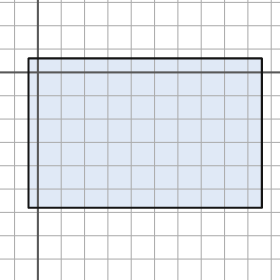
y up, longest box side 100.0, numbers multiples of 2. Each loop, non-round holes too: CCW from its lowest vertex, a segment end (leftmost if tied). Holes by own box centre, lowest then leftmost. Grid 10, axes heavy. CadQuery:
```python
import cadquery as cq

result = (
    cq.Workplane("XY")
    .moveTo(-4.0, -58.0)
    .lineTo(96.0, -58.0)
    .lineTo(96.0, 6.0)
    .lineTo(-4.0, 6.0)
    .close()
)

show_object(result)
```